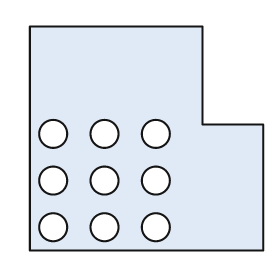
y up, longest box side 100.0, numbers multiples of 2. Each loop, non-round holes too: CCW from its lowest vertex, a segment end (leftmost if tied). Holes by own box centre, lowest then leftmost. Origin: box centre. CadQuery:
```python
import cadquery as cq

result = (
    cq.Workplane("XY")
    .moveTo(-50.0, -48.0)
    .lineTo(50.0, -48.0)
    .lineTo(50.0, 6.0)
    .lineTo(24.0, 6.0)
    .lineTo(24.0, 48.0)
    .lineTo(-50.0, 48.0)
    .close()
    .moveTo(-40.0, -38.0)
    .circle(6.0)
    .moveTo(-18.0, -38.0)
    .circle(6.0)
    .moveTo(4.0, -38.0)
    .circle(6.0)
    .moveTo(-40.0, -18.0)
    .circle(6.0)
    .moveTo(-18.0, -18.0)
    .circle(6.0)
    .moveTo(4.0, -18.0)
    .circle(6.0)
    .moveTo(-40.0, 2.0)
    .circle(6.0)
    .moveTo(-18.0, 2.0)
    .circle(6.0)
    .moveTo(4.0, 2.0)
    .circle(6.0)
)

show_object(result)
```